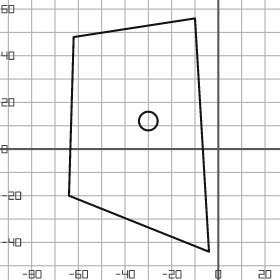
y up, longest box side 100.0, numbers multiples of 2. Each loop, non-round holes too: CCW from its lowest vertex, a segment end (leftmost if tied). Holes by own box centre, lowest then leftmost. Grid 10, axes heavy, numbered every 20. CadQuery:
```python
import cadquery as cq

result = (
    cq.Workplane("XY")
    .moveTo(-4.0, -44.0)
    .lineTo(-10.0, 56.0)
    .lineTo(-62.0, 48.0)
    .lineTo(-64.0, -20.0)
    .close()
    .moveTo(-30.0, 12.0)
    .circle(4.0)
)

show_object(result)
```